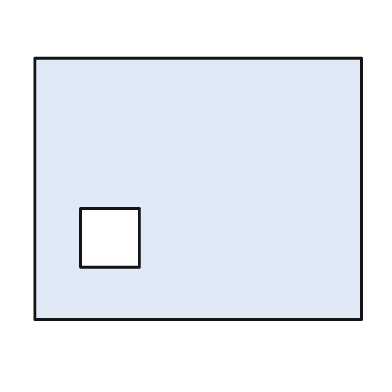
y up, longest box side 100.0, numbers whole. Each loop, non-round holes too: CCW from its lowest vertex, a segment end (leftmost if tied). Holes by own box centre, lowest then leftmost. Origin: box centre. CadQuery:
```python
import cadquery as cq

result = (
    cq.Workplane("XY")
    .moveTo(-50.0, -40.0)
    .lineTo(50.0, -40.0)
    .lineTo(50.0, 40.0)
    .lineTo(-50.0, 40.0)
    .close()
    .moveTo(-36.0, -24.0)
    .lineTo(-18.0, -24.0)
    .lineTo(-18.0, -6.0)
    .lineTo(-36.0, -6.0)
    .close()
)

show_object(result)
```